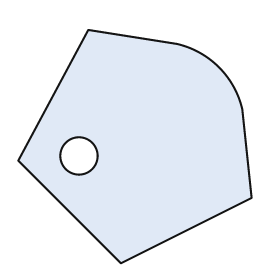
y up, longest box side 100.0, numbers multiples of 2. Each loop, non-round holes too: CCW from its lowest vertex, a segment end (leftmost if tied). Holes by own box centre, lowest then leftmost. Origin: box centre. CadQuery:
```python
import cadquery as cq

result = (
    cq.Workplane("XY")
    .moveTo(-6.0, -50.0)
    .lineTo(50.0, -22.0)
    .lineTo(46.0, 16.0)
    .threePointArc((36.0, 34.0), (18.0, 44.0))
    .lineTo(-20.0, 50.0)
    .lineTo(-50.0, -6.0)
    .close()
    .moveTo(-24.0, -4.0)
    .circle(8.0)
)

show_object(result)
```